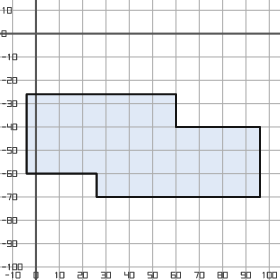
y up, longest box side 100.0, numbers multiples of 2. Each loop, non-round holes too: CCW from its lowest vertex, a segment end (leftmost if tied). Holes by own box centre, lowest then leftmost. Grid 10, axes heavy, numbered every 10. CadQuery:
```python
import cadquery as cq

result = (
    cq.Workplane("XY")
    .moveTo(26.0, -70.0)
    .lineTo(96.0, -70.0)
    .lineTo(96.0, -40.0)
    .lineTo(60.0, -40.0)
    .lineTo(60.0, -26.0)
    .lineTo(-4.0, -26.0)
    .lineTo(-4.0, -60.0)
    .lineTo(26.0, -60.0)
    .close()
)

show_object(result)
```